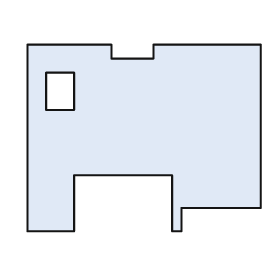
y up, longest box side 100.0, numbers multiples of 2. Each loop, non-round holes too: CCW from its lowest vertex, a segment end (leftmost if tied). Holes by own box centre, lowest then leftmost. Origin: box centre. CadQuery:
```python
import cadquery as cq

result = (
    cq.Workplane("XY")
    .moveTo(-50.0, -40.0)
    .lineTo(-30.0, -40.0)
    .lineTo(-30.0, -16.0)
    .lineTo(12.0, -16.0)
    .lineTo(12.0, -40.0)
    .lineTo(16.0, -40.0)
    .lineTo(16.0, -30.0)
    .lineTo(50.0, -30.0)
    .lineTo(50.0, 40.0)
    .lineTo(4.0, 40.0)
    .lineTo(4.0, 34.0)
    .lineTo(-14.0, 34.0)
    .lineTo(-14.0, 40.0)
    .lineTo(-50.0, 40.0)
    .close()
    .moveTo(-42.0, 12.0)
    .lineTo(-30.0, 12.0)
    .lineTo(-30.0, 28.0)
    .lineTo(-42.0, 28.0)
    .close()
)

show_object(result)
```